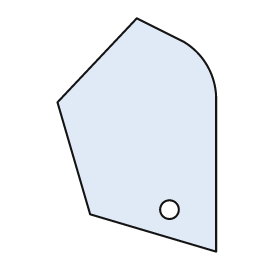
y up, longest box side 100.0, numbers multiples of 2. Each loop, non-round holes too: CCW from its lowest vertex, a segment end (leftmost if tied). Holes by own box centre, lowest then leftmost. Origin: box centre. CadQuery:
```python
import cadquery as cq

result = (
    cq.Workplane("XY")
    .moveTo(34.0, -50.0)
    .lineTo(34.0, 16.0)
    .threePointArc((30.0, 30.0), (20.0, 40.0))
    .lineTo(0.0, 50.0)
    .lineTo(-34.0, 14.0)
    .lineTo(-20.0, -34.0)
    .close()
    .moveTo(14.0, -32.0)
    .circle(4.0)
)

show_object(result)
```